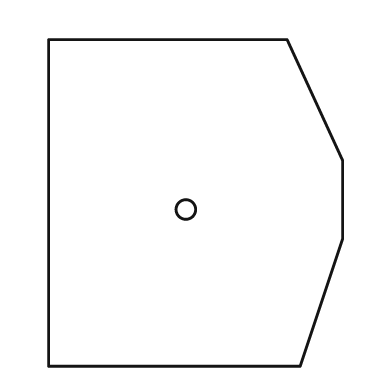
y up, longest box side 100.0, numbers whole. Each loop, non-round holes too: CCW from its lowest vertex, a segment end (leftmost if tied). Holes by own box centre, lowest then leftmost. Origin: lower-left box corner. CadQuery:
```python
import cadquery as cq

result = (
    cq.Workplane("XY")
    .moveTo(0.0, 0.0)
    .lineTo(77.0, 0.0)
    .lineTo(90.0, 39.0)
    .lineTo(90.0, 63.0)
    .lineTo(73.0, 100.0)
    .lineTo(0.0, 100.0)
    .close()
    .moveTo(42.0, 48.0)
    .circle(3.0)
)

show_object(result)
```